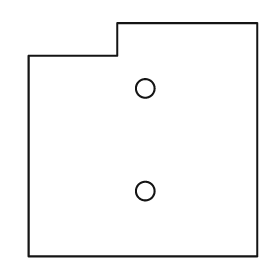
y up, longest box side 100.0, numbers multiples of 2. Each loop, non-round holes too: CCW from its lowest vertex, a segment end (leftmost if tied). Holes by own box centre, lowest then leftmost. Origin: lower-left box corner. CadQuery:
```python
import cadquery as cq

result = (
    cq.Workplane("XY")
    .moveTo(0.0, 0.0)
    .lineTo(98.0, 0.0)
    .lineTo(98.0, 100.0)
    .lineTo(38.0, 100.0)
    .lineTo(38.0, 86.0)
    .lineTo(0.0, 86.0)
    .close()
    .moveTo(50.0, 28.0)
    .circle(4.0)
    .moveTo(50.0, 72.0)
    .circle(4.0)
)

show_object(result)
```